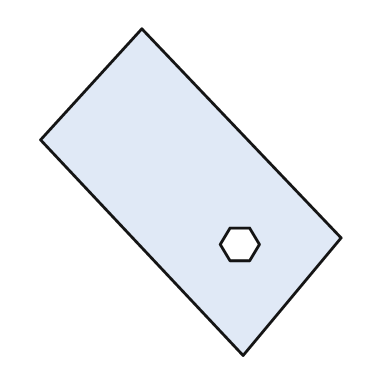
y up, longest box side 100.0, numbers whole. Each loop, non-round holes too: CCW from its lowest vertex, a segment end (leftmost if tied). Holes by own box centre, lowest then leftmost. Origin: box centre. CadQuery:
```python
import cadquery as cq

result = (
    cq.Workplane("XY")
    .moveTo(16.0, -50.0)
    .lineTo(46.0, -14.0)
    .lineTo(-15.0, 50.0)
    .lineTo(-46.0, 16.0)
    .close()
    .moveTo(12.0, -21.0)
    .lineTo(18.0, -21.0)
    .lineTo(21.0, -16.0)
    .lineTo(18.0, -11.0)
    .lineTo(12.0, -11.0)
    .lineTo(9.0, -16.0)
    .close()
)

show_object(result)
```